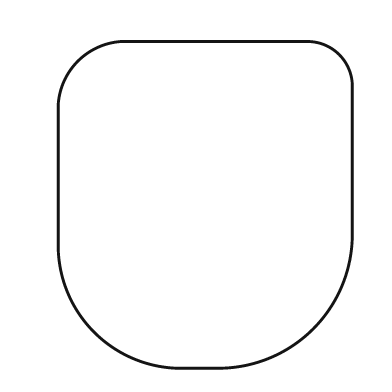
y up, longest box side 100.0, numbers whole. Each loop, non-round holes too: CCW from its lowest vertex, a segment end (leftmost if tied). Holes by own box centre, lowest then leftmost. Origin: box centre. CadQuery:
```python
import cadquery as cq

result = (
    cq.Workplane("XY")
    .moveTo(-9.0, -50.0)
    .lineTo(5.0, -50.0)
    .threePointArc((33.0, -38.0), (45.0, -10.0))
    .lineTo(45.0, 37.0)
    .threePointArc((41.0, 46.0), (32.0, 50.0))
    .lineTo(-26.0, 50.0)
    .threePointArc((-39.0, 44.0), (-45.0, 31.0))
    .lineTo(-45.0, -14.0)
    .threePointArc((-34.0, -39.0), (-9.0, -50.0))
    .close()
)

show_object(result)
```